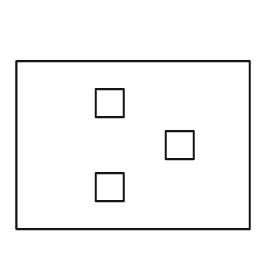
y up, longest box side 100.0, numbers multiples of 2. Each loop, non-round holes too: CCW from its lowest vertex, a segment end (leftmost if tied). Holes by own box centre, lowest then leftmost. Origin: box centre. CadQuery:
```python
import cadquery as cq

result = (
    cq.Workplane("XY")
    .moveTo(-50.0, -36.0)
    .lineTo(50.0, -36.0)
    .lineTo(50.0, 36.0)
    .lineTo(-50.0, 36.0)
    .close()
    .moveTo(-16.0, -24.0)
    .lineTo(-4.0, -24.0)
    .lineTo(-4.0, -12.0)
    .lineTo(-16.0, -12.0)
    .close()
    .moveTo(14.0, -6.0)
    .lineTo(26.0, -6.0)
    .lineTo(26.0, 6.0)
    .lineTo(14.0, 6.0)
    .close()
    .moveTo(-16.0, 12.0)
    .lineTo(-4.0, 12.0)
    .lineTo(-4.0, 24.0)
    .lineTo(-16.0, 24.0)
    .close()
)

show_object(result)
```